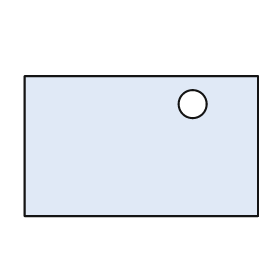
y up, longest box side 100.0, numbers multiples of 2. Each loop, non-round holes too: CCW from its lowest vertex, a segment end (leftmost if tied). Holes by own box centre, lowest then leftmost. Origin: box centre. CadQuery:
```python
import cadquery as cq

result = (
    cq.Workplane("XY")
    .moveTo(-50.0, -30.0)
    .lineTo(50.0, -30.0)
    .lineTo(50.0, 30.0)
    .lineTo(-50.0, 30.0)
    .close()
    .moveTo(22.0, 18.0)
    .circle(6.0)
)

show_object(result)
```